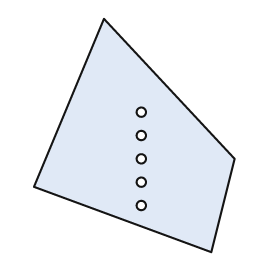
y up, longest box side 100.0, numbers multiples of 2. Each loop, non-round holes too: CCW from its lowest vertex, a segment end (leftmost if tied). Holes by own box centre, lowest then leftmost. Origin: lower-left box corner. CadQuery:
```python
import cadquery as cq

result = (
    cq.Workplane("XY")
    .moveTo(76.0, 0.0)
    .lineTo(86.0, 40.0)
    .lineTo(30.0, 100.0)
    .lineTo(0.0, 28.0)
    .close()
    .moveTo(46.0, 20.0)
    .circle(2.0)
    .moveTo(46.0, 30.0)
    .circle(2.0)
    .moveTo(46.0, 40.0)
    .circle(2.0)
    .moveTo(46.0, 50.0)
    .circle(2.0)
    .moveTo(46.0, 60.0)
    .circle(2.0)
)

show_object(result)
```